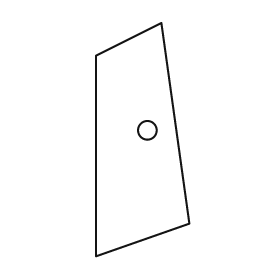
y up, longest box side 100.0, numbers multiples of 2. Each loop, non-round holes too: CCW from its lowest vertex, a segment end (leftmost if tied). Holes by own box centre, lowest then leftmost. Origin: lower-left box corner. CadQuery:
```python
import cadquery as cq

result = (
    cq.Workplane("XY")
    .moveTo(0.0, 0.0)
    .lineTo(40.0, 14.0)
    .lineTo(28.0, 100.0)
    .lineTo(0.0, 86.0)
    .close()
    .moveTo(22.0, 54.0)
    .circle(4.0)
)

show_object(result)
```